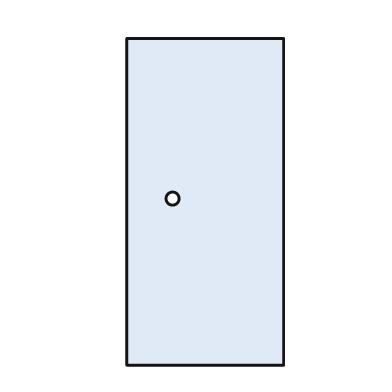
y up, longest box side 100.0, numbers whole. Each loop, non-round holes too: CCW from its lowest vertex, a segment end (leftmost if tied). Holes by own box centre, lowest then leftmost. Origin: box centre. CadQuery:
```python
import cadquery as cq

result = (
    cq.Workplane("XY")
    .moveTo(-24.0, -50.0)
    .lineTo(24.0, -50.0)
    .lineTo(24.0, 50.0)
    .lineTo(-24.0, 50.0)
    .close()
    .moveTo(-10.0, 1.0)
    .circle(2.0)
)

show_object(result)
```